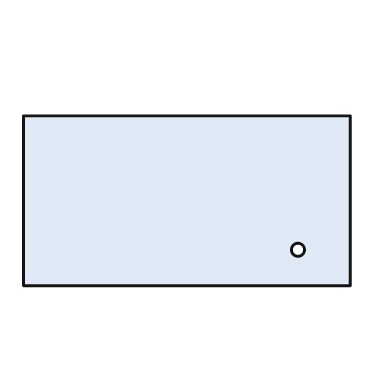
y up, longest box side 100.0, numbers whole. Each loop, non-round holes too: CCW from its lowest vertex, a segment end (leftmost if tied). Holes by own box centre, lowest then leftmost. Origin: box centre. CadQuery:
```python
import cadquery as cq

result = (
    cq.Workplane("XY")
    .moveTo(-50.0, -26.0)
    .lineTo(50.0, -26.0)
    .lineTo(50.0, 26.0)
    .lineTo(-50.0, 26.0)
    .close()
    .moveTo(34.0, -15.0)
    .circle(2.0)
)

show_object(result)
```